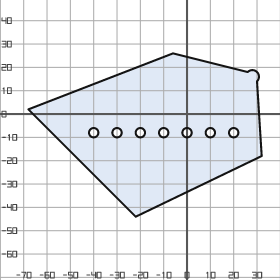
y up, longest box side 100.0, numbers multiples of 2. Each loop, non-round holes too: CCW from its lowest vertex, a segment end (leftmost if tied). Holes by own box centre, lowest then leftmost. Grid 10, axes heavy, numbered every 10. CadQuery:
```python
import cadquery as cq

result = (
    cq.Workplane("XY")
    .moveTo(-22.0, -44.0)
    .lineTo(32.0, -18.0)
    .lineTo(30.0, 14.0)
    .threePointArc((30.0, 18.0), (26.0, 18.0))
    .lineTo(-6.0, 26.0)
    .lineTo(-68.0, 2.0)
    .close()
    .moveTo(-40.0, -8.0)
    .circle(2.0)
    .moveTo(-30.0, -8.0)
    .circle(2.0)
    .moveTo(-20.0, -8.0)
    .circle(2.0)
    .moveTo(-10.0, -8.0)
    .circle(2.0)
    .moveTo(0.0, -8.0)
    .circle(2.0)
    .moveTo(10.0, -8.0)
    .circle(2.0)
    .moveTo(20.0, -8.0)
    .circle(2.0)
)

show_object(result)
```